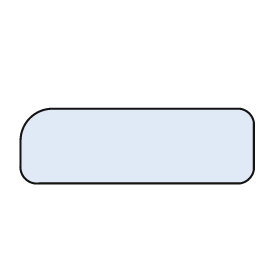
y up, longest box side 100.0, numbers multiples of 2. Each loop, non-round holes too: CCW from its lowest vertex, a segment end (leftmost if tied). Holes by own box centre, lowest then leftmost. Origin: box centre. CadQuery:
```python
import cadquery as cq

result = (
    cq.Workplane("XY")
    .moveTo(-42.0, -16.0)
    .lineTo(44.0, -16.0)
    .threePointArc((48.0, -14.0), (50.0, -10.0))
    .lineTo(50.0, 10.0)
    .threePointArc((48.0, 14.0), (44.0, 16.0))
    .lineTo(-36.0, 16.0)
    .threePointArc((-46.0, 12.0), (-50.0, 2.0))
    .lineTo(-50.0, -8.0)
    .threePointArc((-48.0, -14.0), (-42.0, -16.0))
    .close()
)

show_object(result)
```